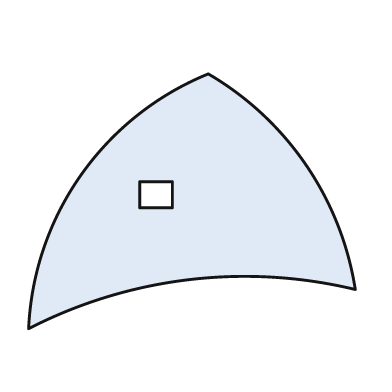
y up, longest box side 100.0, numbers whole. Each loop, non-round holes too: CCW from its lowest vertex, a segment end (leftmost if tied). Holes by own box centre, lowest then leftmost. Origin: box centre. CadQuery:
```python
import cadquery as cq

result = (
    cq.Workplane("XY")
    .moveTo(-50.0, -39.0)
    .threePointArc((-1.0, -24.0), (50.0, -27.0))
    .threePointArc((35.0, 11.0), (5.0, 39.0))
    .threePointArc((-34.0, 8.0), (-50.0, -39.0))
    .close()
    .moveTo(-16.0, -2.0)
    .lineTo(-6.0, -2.0)
    .lineTo(-6.0, 6.0)
    .lineTo(-16.0, 6.0)
    .close()
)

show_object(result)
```